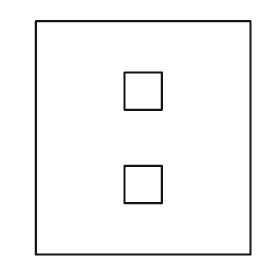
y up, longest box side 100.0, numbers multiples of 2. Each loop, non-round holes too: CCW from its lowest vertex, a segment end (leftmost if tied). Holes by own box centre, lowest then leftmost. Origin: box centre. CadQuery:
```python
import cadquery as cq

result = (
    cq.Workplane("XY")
    .moveTo(-46.0, -50.0)
    .lineTo(46.0, -50.0)
    .lineTo(46.0, 50.0)
    .lineTo(-46.0, 50.0)
    .close()
    .moveTo(-8.0, -28.0)
    .lineTo(8.0, -28.0)
    .lineTo(8.0, -12.0)
    .lineTo(-8.0, -12.0)
    .close()
    .moveTo(-8.0, 12.0)
    .lineTo(8.0, 12.0)
    .lineTo(8.0, 28.0)
    .lineTo(-8.0, 28.0)
    .close()
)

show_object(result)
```